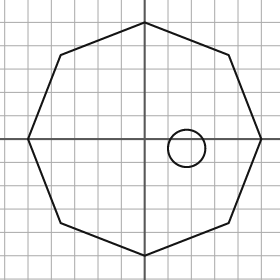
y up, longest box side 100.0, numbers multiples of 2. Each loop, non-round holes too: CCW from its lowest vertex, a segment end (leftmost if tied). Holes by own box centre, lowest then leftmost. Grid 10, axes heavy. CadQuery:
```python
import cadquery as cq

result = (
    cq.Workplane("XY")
    .moveTo(0.0, -50.0)
    .lineTo(36.0, -36.0)
    .lineTo(50.0, 0.0)
    .lineTo(36.0, 36.0)
    .lineTo(0.0, 50.0)
    .lineTo(-36.0, 36.0)
    .lineTo(-50.0, 0.0)
    .lineTo(-36.0, -36.0)
    .close()
    .moveTo(18.0, -4.0)
    .circle(8.0)
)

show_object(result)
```